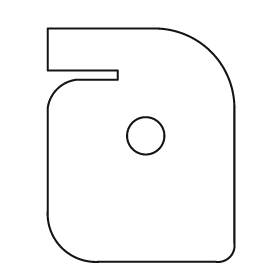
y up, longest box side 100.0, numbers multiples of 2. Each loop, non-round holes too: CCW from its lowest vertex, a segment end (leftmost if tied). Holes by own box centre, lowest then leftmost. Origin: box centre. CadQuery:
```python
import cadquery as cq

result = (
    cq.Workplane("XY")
    .moveTo(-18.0, -50.0)
    .lineTo(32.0, -50.0)
    .threePointArc((38.0, -48.0), (40.0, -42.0))
    .lineTo(40.0, 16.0)
    .threePointArc((30.0, 40.0), (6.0, 50.0))
    .lineTo(-40.0, 50.0)
    .lineTo(-40.0, 32.0)
    .lineTo(-10.0, 32.0)
    .lineTo(-10.0, 28.0)
    .lineTo(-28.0, 28.0)
    .threePointArc((-36.0, 24.0), (-40.0, 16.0))
    .lineTo(-40.0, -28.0)
    .threePointArc((-34.0, -44.0), (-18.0, -50.0))
    .close()
    .moveTo(2.0, 4.0)
    .circle(8.0)
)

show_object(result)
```